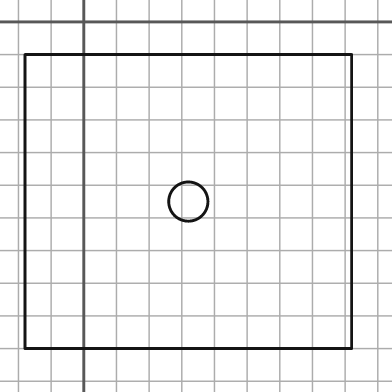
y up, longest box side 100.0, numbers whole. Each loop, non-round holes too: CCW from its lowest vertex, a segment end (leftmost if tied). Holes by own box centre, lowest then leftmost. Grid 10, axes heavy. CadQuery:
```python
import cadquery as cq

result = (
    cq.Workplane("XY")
    .moveTo(-18.0, -100.0)
    .lineTo(82.0, -100.0)
    .lineTo(82.0, -10.0)
    .lineTo(-18.0, -10.0)
    .close()
    .moveTo(32.0, -55.0)
    .circle(6.0)
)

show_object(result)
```